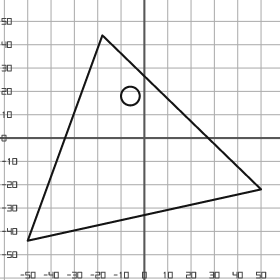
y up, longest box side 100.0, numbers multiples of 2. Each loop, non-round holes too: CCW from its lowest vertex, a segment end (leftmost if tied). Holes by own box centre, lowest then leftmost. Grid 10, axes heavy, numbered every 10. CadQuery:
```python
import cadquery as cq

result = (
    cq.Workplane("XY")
    .moveTo(-50.0, -44.0)
    .lineTo(50.0, -22.0)
    .lineTo(-18.0, 44.0)
    .close()
    .moveTo(-6.0, 18.0)
    .circle(4.0)
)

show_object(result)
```